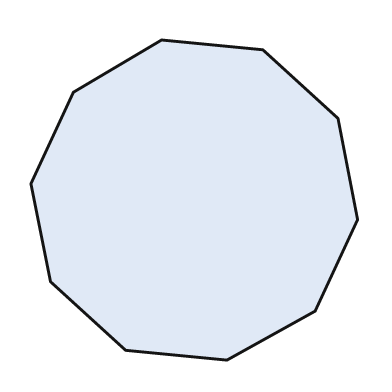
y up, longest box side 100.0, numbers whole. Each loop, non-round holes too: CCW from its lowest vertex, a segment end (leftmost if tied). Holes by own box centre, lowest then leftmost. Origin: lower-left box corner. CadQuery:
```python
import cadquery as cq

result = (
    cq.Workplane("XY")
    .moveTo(60.0, 0.0)
    .lineTo(87.0, 15.0)
    .lineTo(100.0, 43.0)
    .lineTo(94.0, 74.0)
    .lineTo(71.0, 95.0)
    .lineTo(40.0, 98.0)
    .lineTo(13.0, 82.0)
    .lineTo(0.0, 54.0)
    .lineTo(6.0, 24.0)
    .lineTo(29.0, 3.0)
    .close()
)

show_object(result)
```